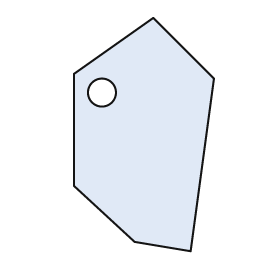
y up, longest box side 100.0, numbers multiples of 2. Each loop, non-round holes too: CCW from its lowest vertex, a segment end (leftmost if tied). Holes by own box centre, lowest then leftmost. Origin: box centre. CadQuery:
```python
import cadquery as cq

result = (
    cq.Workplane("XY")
    .moveTo(20.0, -50.0)
    .lineTo(30.0, 24.0)
    .lineTo(4.0, 50.0)
    .lineTo(-30.0, 26.0)
    .lineTo(-30.0, -22.0)
    .lineTo(-4.0, -46.0)
    .close()
    .moveTo(-18.0, 18.0)
    .circle(6.0)
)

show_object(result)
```